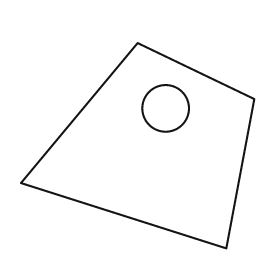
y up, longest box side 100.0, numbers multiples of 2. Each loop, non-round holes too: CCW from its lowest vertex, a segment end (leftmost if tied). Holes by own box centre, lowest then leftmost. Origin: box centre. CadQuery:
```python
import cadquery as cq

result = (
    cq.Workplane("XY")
    .moveTo(38.0, -44.0)
    .lineTo(50.0, 20.0)
    .lineTo(0.0, 44.0)
    .lineTo(-50.0, -16.0)
    .close()
    .moveTo(12.0, 16.0)
    .circle(10.0)
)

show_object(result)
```